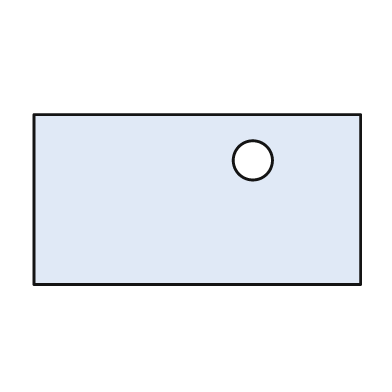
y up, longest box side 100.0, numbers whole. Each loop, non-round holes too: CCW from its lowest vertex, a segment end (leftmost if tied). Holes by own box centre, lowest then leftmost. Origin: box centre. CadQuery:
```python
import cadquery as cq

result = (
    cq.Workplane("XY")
    .moveTo(-50.0, -26.0)
    .lineTo(50.0, -26.0)
    .lineTo(50.0, 26.0)
    .lineTo(-50.0, 26.0)
    .close()
    .moveTo(17.0, 12.0)
    .circle(6.0)
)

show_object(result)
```